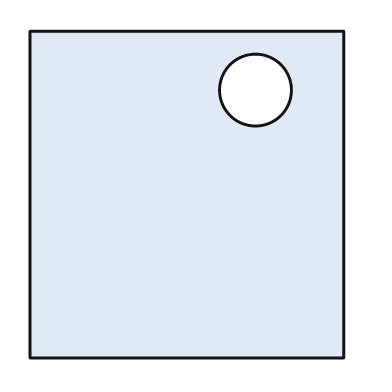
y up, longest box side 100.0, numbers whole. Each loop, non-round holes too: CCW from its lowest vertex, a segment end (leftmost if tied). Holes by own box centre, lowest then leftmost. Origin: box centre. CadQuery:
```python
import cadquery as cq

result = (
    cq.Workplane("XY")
    .moveTo(-48.0, -50.0)
    .lineTo(48.0, -50.0)
    .lineTo(48.0, 50.0)
    .lineTo(-48.0, 50.0)
    .close()
    .moveTo(21.0, 32.0)
    .circle(11.0)
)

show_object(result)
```